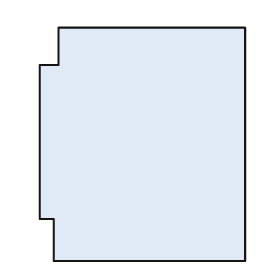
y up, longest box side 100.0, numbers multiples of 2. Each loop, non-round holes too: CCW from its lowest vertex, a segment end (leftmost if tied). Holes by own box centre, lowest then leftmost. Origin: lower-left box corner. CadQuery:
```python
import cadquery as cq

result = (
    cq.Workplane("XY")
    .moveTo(6.0, 0.0)
    .lineTo(88.0, 0.0)
    .lineTo(88.0, 100.0)
    .lineTo(8.0, 100.0)
    .lineTo(8.0, 84.0)
    .lineTo(0.0, 84.0)
    .lineTo(0.0, 18.0)
    .lineTo(6.0, 18.0)
    .close()
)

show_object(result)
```